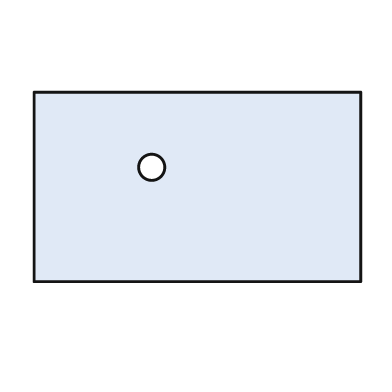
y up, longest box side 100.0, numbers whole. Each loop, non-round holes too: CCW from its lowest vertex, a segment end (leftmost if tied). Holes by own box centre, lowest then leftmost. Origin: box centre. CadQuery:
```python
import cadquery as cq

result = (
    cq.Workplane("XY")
    .moveTo(-50.0, -29.0)
    .lineTo(50.0, -29.0)
    .lineTo(50.0, 29.0)
    .lineTo(-50.0, 29.0)
    .close()
    .moveTo(-14.0, 6.0)
    .circle(4.0)
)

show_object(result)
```